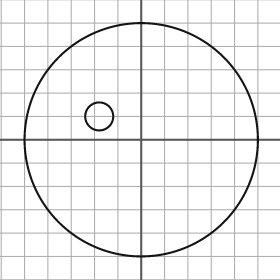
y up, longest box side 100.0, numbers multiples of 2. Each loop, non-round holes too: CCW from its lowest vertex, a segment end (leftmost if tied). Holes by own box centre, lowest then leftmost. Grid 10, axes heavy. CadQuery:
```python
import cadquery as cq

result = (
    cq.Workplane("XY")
    .moveTo(0.0, 0.0)
    .circle(50.0)
    .moveTo(-18.0, 10.0)
    .circle(6.0)
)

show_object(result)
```